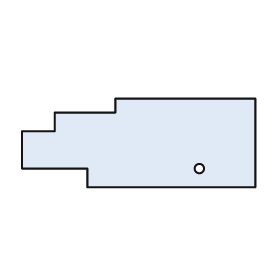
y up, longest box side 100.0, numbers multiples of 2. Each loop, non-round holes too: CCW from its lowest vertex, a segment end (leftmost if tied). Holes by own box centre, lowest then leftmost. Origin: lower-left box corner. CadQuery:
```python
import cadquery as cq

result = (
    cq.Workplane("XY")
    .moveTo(28.0, 0.0)
    .lineTo(100.0, 0.0)
    .lineTo(100.0, 38.0)
    .lineTo(40.0, 38.0)
    .lineTo(40.0, 32.0)
    .lineTo(14.0, 32.0)
    .lineTo(14.0, 24.0)
    .lineTo(0.0, 24.0)
    .lineTo(0.0, 8.0)
    .lineTo(28.0, 8.0)
    .close()
    .moveTo(76.0, 8.0)
    .circle(2.0)
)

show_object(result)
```